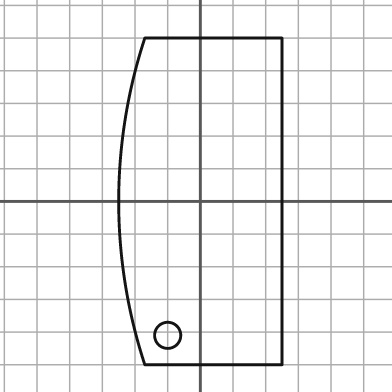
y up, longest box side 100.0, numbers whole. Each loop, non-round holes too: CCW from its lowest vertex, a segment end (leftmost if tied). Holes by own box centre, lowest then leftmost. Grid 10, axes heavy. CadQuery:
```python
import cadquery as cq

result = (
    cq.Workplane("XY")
    .moveTo(-17.0, -50.0)
    .lineTo(25.0, -50.0)
    .lineTo(25.0, 50.0)
    .lineTo(-17.0, 50.0)
    .threePointArc((-25.0, 0.0), (-17.0, -50.0))
    .close()
    .moveTo(-10.0, -41.0)
    .circle(4.0)
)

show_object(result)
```